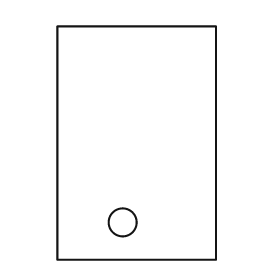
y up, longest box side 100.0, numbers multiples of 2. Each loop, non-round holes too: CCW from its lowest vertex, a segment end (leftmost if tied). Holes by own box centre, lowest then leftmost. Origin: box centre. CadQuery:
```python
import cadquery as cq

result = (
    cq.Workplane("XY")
    .moveTo(-34.0, -50.0)
    .lineTo(34.0, -50.0)
    .lineTo(34.0, 50.0)
    .lineTo(-34.0, 50.0)
    .close()
    .moveTo(-6.0, -34.0)
    .circle(6.0)
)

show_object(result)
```